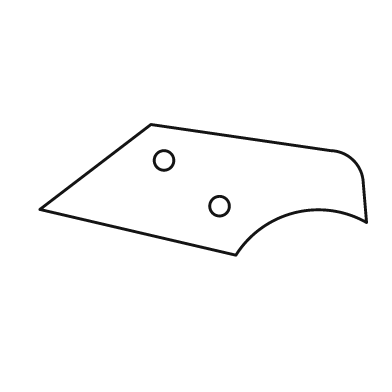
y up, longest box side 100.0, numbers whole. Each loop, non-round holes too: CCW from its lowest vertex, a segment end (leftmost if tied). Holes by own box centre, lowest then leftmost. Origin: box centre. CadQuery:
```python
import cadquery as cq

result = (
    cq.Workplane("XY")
    .moveTo(10.0, -20.0)
    .threePointArc((28.0, -7.0), (50.0, -10.0))
    .lineTo(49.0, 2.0)
    .threePointArc((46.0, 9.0), (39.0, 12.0))
    .lineTo(-16.0, 20.0)
    .lineTo(-50.0, -6.0)
    .close()
    .moveTo(5.0, -5.0)
    .circle(3.0)
    .moveTo(-12.0, 9.0)
    .circle(3.0)
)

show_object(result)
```